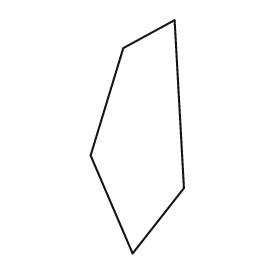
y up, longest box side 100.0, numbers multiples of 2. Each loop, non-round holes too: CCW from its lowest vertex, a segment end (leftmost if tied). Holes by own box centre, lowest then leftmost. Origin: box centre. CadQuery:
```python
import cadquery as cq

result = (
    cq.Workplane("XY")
    .moveTo(-2.0, -50.0)
    .lineTo(20.0, -22.0)
    .lineTo(16.0, 50.0)
    .lineTo(-6.0, 38.0)
    .lineTo(-20.0, -8.0)
    .close()
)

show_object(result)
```